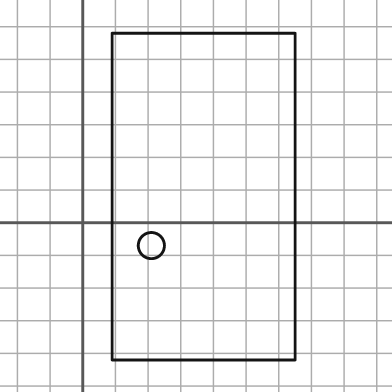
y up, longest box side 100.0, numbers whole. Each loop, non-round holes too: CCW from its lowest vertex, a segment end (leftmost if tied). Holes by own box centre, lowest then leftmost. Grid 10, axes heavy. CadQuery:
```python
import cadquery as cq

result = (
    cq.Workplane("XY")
    .moveTo(9.0, -42.0)
    .lineTo(65.0, -42.0)
    .lineTo(65.0, 58.0)
    .lineTo(9.0, 58.0)
    .close()
    .moveTo(21.0, -7.0)
    .circle(4.0)
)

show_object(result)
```